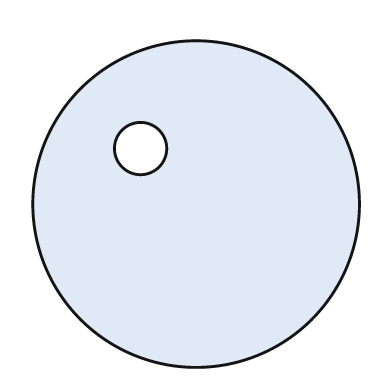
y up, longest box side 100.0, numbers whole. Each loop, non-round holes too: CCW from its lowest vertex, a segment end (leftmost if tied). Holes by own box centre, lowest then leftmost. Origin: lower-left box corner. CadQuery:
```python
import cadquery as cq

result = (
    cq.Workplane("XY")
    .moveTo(50.0, 50.0)
    .circle(50.0)
    .moveTo(33.0, 67.0)
    .circle(8.0)
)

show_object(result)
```